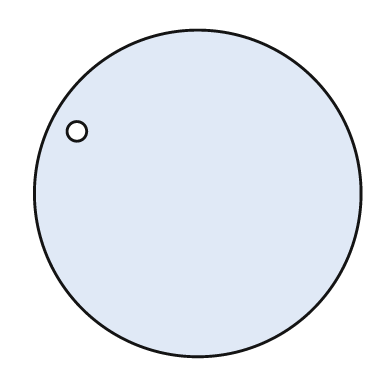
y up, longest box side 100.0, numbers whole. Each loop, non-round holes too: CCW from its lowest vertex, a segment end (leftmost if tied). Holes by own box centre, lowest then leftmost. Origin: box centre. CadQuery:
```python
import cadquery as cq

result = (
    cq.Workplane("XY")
    .moveTo(0.0, 0.0)
    .circle(50.0)
    .moveTo(-37.0, 19.0)
    .circle(3.0)
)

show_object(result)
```